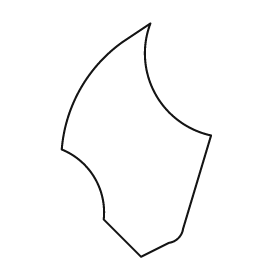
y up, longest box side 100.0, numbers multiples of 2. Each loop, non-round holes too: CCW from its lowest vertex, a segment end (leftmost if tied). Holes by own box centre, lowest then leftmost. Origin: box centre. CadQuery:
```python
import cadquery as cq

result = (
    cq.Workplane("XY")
    .moveTo(2.0, -50.0)
    .lineTo(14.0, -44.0)
    .threePointArc((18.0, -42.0), (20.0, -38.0))
    .lineTo(32.0, 2.0)
    .threePointArc((8.0, 20.0), (6.0, 50.0))
    .lineTo(-6.0, 42.0)
    .threePointArc((-24.0, 22.0), (-32.0, -4.0))
    .threePointArc((-18.0, -16.0), (-14.0, -34.0))
    .close()
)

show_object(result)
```